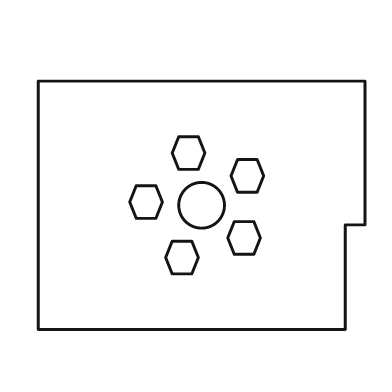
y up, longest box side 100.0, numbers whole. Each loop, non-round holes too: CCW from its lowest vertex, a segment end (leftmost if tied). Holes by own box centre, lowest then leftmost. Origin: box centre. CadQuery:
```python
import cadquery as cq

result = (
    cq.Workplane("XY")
    .moveTo(-50.0, -38.0)
    .lineTo(44.0, -38.0)
    .lineTo(44.0, -6.0)
    .lineTo(50.0, -6.0)
    .lineTo(50.0, 38.0)
    .lineTo(-50.0, 38.0)
    .close()
    .moveTo(-9.0, -21.0)
    .lineTo(-3.0, -21.0)
    .lineTo(-1.0, -16.0)
    .lineTo(-3.0, -11.0)
    .lineTo(-9.0, -11.0)
    .lineTo(-11.0, -16.0)
    .close()
    .moveTo(10.0, -15.0)
    .lineTo(16.0, -15.0)
    .lineTo(18.0, -10.0)
    .lineTo(16.0, -5.0)
    .lineTo(10.0, -5.0)
    .lineTo(8.0, -10.0)
    .close()
    .moveTo(0.0, 0.0)
    .circle(7.0)
    .moveTo(-20.0, -4.0)
    .lineTo(-14.0, -4.0)
    .lineTo(-12.0, 1.0)
    .lineTo(-14.0, 6.0)
    .lineTo(-20.0, 6.0)
    .lineTo(-22.0, 1.0)
    .close()
    .moveTo(11.0, 4.0)
    .lineTo(17.0, 4.0)
    .lineTo(19.0, 9.0)
    .lineTo(17.0, 14.0)
    .lineTo(11.0, 14.0)
    .lineTo(9.0, 9.0)
    .close()
    .moveTo(-7.0, 11.0)
    .lineTo(-1.0, 11.0)
    .lineTo(1.0, 16.0)
    .lineTo(-1.0, 21.0)
    .lineTo(-7.0, 21.0)
    .lineTo(-9.0, 16.0)
    .close()
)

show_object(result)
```